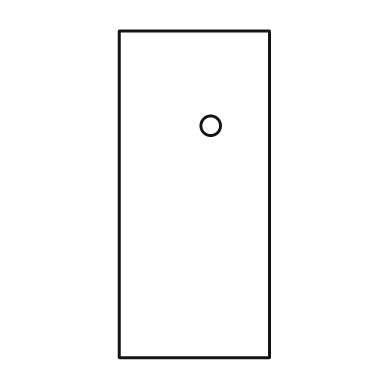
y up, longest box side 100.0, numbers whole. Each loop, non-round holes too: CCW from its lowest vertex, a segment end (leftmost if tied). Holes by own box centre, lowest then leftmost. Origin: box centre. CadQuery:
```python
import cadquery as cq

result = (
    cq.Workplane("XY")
    .moveTo(-23.0, -50.0)
    .lineTo(23.0, -50.0)
    .lineTo(23.0, 50.0)
    .lineTo(-23.0, 50.0)
    .close()
    .moveTo(5.0, 21.0)
    .circle(3.0)
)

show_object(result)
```